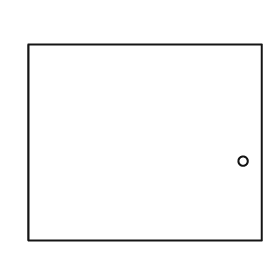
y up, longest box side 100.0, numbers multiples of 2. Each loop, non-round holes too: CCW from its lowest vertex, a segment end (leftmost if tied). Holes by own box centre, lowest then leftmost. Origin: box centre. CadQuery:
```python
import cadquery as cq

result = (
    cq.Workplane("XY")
    .moveTo(-50.0, -42.0)
    .lineTo(50.0, -42.0)
    .lineTo(50.0, 42.0)
    .lineTo(-50.0, 42.0)
    .close()
    .moveTo(42.0, -8.0)
    .circle(2.0)
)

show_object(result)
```